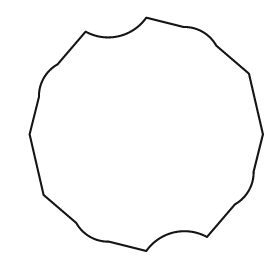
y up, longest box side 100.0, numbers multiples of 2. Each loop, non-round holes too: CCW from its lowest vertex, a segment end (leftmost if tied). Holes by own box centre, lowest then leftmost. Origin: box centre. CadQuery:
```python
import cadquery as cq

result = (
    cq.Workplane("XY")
    .moveTo(0.0, -50.0)
    .threePointArc((12.0, -42.0), (26.0, -44.0))
    .lineTo(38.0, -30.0)
    .threePointArc((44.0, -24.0), (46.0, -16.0))
    .lineTo(50.0, 0.0)
    .lineTo(44.0, 26.0)
    .lineTo(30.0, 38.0)
    .threePointArc((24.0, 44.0), (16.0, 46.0))
    .lineTo(0.0, 50.0)
    .threePointArc((-12.0, 42.0), (-26.0, 44.0))
    .lineTo(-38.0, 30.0)
    .threePointArc((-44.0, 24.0), (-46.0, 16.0))
    .lineTo(-50.0, 0.0)
    .lineTo(-44.0, -26.0)
    .lineTo(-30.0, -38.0)
    .threePointArc((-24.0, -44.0), (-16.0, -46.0))
    .close()
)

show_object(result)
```